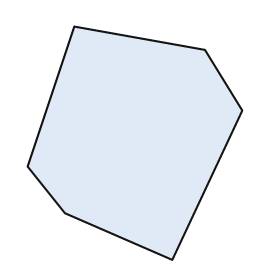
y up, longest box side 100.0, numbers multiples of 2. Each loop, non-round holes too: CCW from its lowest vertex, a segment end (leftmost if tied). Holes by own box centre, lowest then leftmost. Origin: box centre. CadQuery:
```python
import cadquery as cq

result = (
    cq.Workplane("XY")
    .moveTo(16.0, -50.0)
    .lineTo(46.0, 14.0)
    .lineTo(30.0, 40.0)
    .lineTo(-26.0, 50.0)
    .lineTo(-46.0, -10.0)
    .lineTo(-30.0, -30.0)
    .close()
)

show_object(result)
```